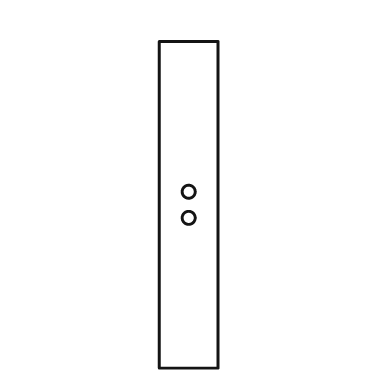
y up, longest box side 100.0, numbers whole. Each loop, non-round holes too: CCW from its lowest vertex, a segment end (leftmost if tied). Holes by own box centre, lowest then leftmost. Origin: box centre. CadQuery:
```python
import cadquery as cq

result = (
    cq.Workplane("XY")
    .moveTo(-9.0, -50.0)
    .lineTo(9.0, -50.0)
    .lineTo(9.0, 50.0)
    .lineTo(-9.0, 50.0)
    .close()
    .moveTo(0.0, -4.0)
    .circle(2.0)
    .moveTo(0.0, 4.0)
    .circle(2.0)
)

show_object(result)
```